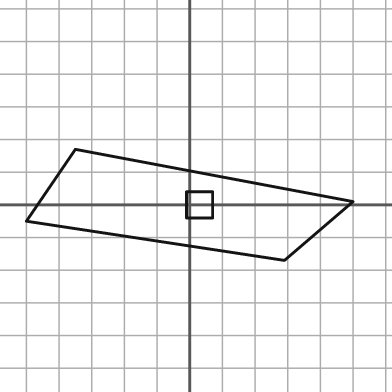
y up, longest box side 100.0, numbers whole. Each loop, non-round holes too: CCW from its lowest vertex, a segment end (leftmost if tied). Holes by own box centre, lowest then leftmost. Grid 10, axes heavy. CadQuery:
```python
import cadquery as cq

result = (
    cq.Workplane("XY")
    .moveTo(29.0, -17.0)
    .lineTo(50.0, 1.0)
    .lineTo(-35.0, 17.0)
    .lineTo(-50.0, -5.0)
    .close()
    .moveTo(-1.0, -4.0)
    .lineTo(7.0, -4.0)
    .lineTo(7.0, 4.0)
    .lineTo(-1.0, 4.0)
    .close()
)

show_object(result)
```